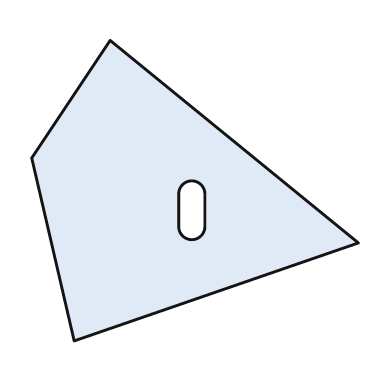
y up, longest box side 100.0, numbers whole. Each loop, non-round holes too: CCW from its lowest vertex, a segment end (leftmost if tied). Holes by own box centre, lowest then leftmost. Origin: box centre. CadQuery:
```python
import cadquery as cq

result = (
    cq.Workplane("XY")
    .moveTo(-37.0, -46.0)
    .lineTo(50.0, -16.0)
    .lineTo(-26.0, 46.0)
    .lineTo(-50.0, 10.0)
    .close()
    .moveTo(-5.0, -11.0)
    .threePointArc((-1.0, -15.0), (3.0, -11.0))
    .lineTo(3.0, -1.0)
    .threePointArc((-1.0, 3.0), (-5.0, -1.0))
    .close()
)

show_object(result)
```